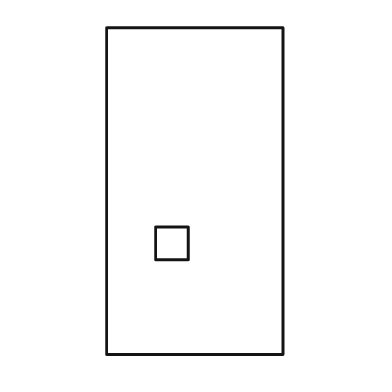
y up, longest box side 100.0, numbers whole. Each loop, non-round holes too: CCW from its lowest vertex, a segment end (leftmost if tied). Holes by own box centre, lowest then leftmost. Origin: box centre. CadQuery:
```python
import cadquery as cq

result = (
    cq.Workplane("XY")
    .moveTo(-27.0, -50.0)
    .lineTo(27.0, -50.0)
    .lineTo(27.0, 50.0)
    .lineTo(-27.0, 50.0)
    .close()
    .moveTo(-12.0, -21.0)
    .lineTo(-2.0, -21.0)
    .lineTo(-2.0, -11.0)
    .lineTo(-12.0, -11.0)
    .close()
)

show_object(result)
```